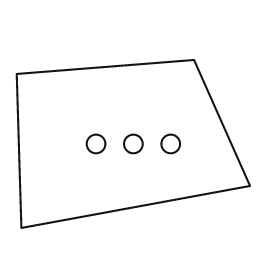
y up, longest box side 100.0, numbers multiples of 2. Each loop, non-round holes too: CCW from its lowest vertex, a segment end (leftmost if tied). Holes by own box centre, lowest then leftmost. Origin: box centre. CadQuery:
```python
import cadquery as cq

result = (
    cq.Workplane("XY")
    .moveTo(-48.0, -36.0)
    .lineTo(50.0, -18.0)
    .lineTo(26.0, 36.0)
    .lineTo(-50.0, 30.0)
    .close()
    .moveTo(-16.0, 0.0)
    .circle(4.0)
    .moveTo(0.0, 0.0)
    .circle(4.0)
    .moveTo(16.0, 0.0)
    .circle(4.0)
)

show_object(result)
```